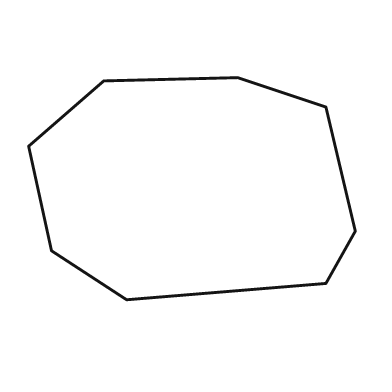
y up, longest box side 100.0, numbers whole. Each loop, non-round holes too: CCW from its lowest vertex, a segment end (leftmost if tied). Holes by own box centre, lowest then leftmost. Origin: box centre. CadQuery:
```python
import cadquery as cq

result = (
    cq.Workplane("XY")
    .moveTo(-20.0, -34.0)
    .lineTo(41.0, -29.0)
    .lineTo(50.0, -13.0)
    .lineTo(41.0, 25.0)
    .lineTo(14.0, 34.0)
    .lineTo(-27.0, 33.0)
    .lineTo(-50.0, 13.0)
    .lineTo(-43.0, -19.0)
    .close()
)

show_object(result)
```